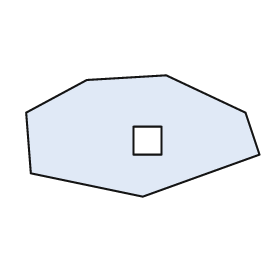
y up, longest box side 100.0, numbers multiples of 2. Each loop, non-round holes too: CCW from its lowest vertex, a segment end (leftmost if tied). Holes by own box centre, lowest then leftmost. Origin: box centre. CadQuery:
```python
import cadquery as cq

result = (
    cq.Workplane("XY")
    .moveTo(0.0, -26.0)
    .lineTo(50.0, -8.0)
    .lineTo(44.0, 10.0)
    .lineTo(10.0, 26.0)
    .lineTo(-24.0, 24.0)
    .lineTo(-50.0, 10.0)
    .lineTo(-48.0, -16.0)
    .close()
    .moveTo(-4.0, -8.0)
    .lineTo(8.0, -8.0)
    .lineTo(8.0, 4.0)
    .lineTo(-4.0, 4.0)
    .close()
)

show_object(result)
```